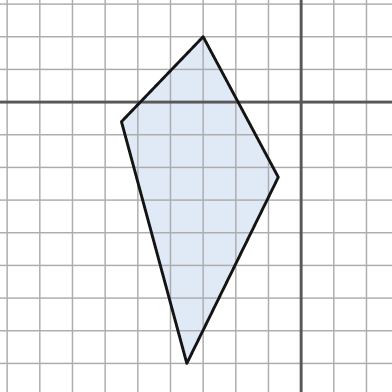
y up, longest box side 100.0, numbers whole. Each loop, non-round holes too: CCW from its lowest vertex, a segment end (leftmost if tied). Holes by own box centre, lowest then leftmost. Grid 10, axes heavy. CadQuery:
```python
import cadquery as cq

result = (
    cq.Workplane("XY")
    .moveTo(-35.0, -80.0)
    .lineTo(-7.0, -23.0)
    .lineTo(-30.0, 20.0)
    .lineTo(-55.0, -6.0)
    .close()
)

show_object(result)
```